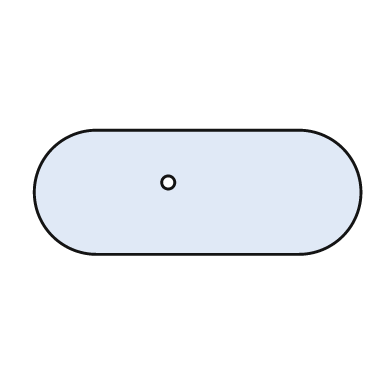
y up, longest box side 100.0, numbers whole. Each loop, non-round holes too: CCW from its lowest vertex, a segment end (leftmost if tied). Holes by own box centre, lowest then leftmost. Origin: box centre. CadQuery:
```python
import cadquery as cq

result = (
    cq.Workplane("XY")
    .moveTo(-31.0, -19.0)
    .lineTo(31.0, -19.0)
    .threePointArc((50.0, 0.0), (31.0, 19.0))
    .lineTo(-31.0, 19.0)
    .threePointArc((-50.0, 0.0), (-31.0, -19.0))
    .close()
    .moveTo(-9.0, 3.0)
    .circle(2.0)
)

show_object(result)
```